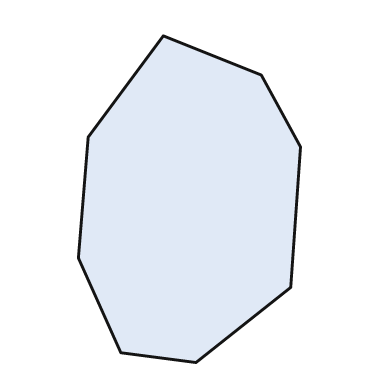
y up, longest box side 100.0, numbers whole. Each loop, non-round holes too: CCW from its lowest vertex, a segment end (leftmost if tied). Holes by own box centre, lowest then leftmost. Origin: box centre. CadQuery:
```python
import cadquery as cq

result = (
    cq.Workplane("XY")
    .moveTo(2.0, -50.0)
    .lineTo(31.0, -27.0)
    .lineTo(34.0, 16.0)
    .lineTo(22.0, 38.0)
    .lineTo(-8.0, 50.0)
    .lineTo(-31.0, 19.0)
    .lineTo(-34.0, -18.0)
    .lineTo(-21.0, -47.0)
    .close()
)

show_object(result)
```